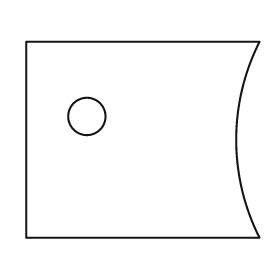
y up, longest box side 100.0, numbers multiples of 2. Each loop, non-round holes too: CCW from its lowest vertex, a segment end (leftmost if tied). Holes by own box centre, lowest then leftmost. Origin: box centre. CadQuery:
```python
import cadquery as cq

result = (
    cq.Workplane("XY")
    .moveTo(-50.0, -42.0)
    .lineTo(50.0, -42.0)
    .threePointArc((40.0, 0.0), (50.0, 42.0))
    .lineTo(-50.0, 42.0)
    .close()
    .moveTo(-24.0, 10.0)
    .circle(8.0)
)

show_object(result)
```